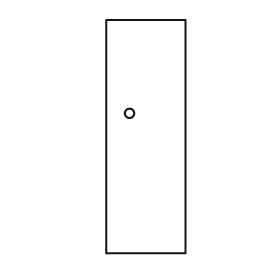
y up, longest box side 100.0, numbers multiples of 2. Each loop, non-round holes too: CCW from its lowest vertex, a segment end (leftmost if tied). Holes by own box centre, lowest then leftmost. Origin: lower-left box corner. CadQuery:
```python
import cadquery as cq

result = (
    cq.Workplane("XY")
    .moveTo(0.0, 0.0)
    .lineTo(34.0, 0.0)
    .lineTo(34.0, 100.0)
    .lineTo(0.0, 100.0)
    .close()
    .moveTo(10.0, 60.0)
    .circle(2.0)
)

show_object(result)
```